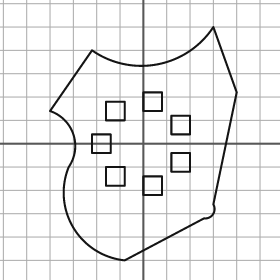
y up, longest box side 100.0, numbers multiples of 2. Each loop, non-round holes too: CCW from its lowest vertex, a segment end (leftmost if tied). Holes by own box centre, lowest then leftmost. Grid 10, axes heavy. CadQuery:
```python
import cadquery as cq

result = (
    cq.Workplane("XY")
    .moveTo(-8.0, -50.0)
    .lineTo(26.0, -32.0)
    .threePointArc((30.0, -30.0), (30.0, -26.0))
    .lineTo(40.0, 22.0)
    .lineTo(30.0, 50.0)
    .threePointArc((6.0, 34.0), (-22.0, 40.0))
    .lineTo(-40.0, 14.0)
    .threePointArc((-30.0, 4.0), (-32.0, -10.0))
    .threePointArc((-30.0, -36.0), (-8.0, -50.0))
    .close()
    .moveTo(0.0, -22.0)
    .lineTo(8.0, -22.0)
    .lineTo(8.0, -14.0)
    .lineTo(0.0, -14.0)
    .close()
    .moveTo(-16.0, -18.0)
    .lineTo(-8.0, -18.0)
    .lineTo(-8.0, -10.0)
    .lineTo(-16.0, -10.0)
    .close()
    .moveTo(12.0, -12.0)
    .lineTo(20.0, -12.0)
    .lineTo(20.0, -4.0)
    .lineTo(12.0, -4.0)
    .close()
    .moveTo(-22.0, -4.0)
    .lineTo(-14.0, -4.0)
    .lineTo(-14.0, 4.0)
    .lineTo(-22.0, 4.0)
    .close()
    .moveTo(12.0, 4.0)
    .lineTo(20.0, 4.0)
    .lineTo(20.0, 12.0)
    .lineTo(12.0, 12.0)
    .close()
    .moveTo(-16.0, 10.0)
    .lineTo(-8.0, 10.0)
    .lineTo(-8.0, 18.0)
    .lineTo(-16.0, 18.0)
    .close()
    .moveTo(0.0, 14.0)
    .lineTo(8.0, 14.0)
    .lineTo(8.0, 22.0)
    .lineTo(0.0, 22.0)
    .close()
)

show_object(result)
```